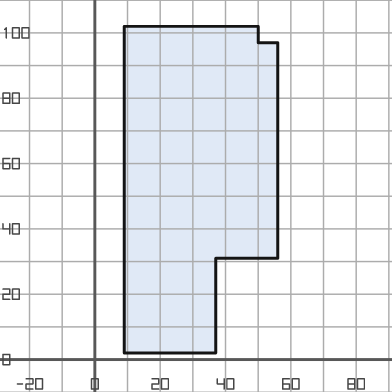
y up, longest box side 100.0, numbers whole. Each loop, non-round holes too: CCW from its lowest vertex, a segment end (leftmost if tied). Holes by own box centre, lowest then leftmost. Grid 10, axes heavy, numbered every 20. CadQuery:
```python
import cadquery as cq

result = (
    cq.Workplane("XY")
    .moveTo(9.0, 2.0)
    .lineTo(37.0, 2.0)
    .lineTo(37.0, 31.0)
    .lineTo(56.0, 31.0)
    .lineTo(56.0, 97.0)
    .lineTo(50.0, 97.0)
    .lineTo(50.0, 102.0)
    .lineTo(9.0, 102.0)
    .close()
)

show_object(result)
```